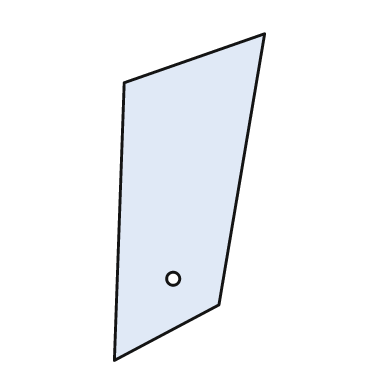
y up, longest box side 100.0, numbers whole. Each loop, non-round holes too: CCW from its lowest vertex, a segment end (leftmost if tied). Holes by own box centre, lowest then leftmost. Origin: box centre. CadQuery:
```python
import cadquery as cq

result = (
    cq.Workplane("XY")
    .moveTo(-23.0, -50.0)
    .lineTo(9.0, -33.0)
    .lineTo(23.0, 50.0)
    .lineTo(-20.0, 35.0)
    .close()
    .moveTo(-5.0, -25.0)
    .circle(2.0)
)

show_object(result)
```